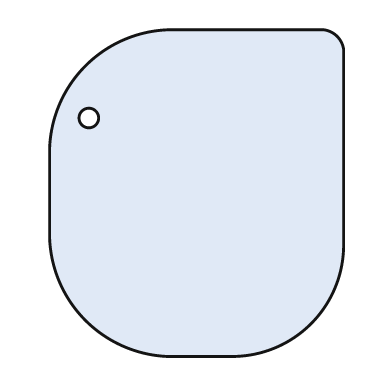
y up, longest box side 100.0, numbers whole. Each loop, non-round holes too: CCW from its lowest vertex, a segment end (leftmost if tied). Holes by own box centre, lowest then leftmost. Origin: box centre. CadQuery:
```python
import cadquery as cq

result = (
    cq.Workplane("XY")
    .moveTo(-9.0, -50.0)
    .lineTo(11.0, -50.0)
    .threePointArc((35.0, -40.0), (45.0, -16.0))
    .lineTo(45.0, 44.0)
    .threePointArc((43.0, 48.0), (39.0, 50.0))
    .lineTo(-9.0, 50.0)
    .threePointArc((-34.0, 39.0), (-45.0, 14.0))
    .lineTo(-45.0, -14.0)
    .threePointArc((-34.0, -39.0), (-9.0, -50.0))
    .close()
    .moveTo(-33.0, 23.0)
    .circle(3.0)
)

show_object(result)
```